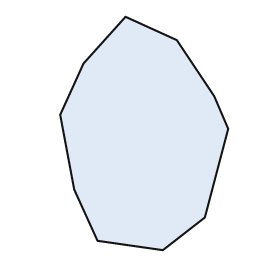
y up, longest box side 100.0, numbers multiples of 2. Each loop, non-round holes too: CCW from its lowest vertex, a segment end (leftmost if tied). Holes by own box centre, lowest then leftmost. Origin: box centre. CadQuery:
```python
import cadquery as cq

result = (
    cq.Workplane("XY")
    .moveTo(8.0, -50.0)
    .lineTo(26.0, -36.0)
    .lineTo(36.0, 2.0)
    .lineTo(30.0, 16.0)
    .lineTo(14.0, 40.0)
    .lineTo(-8.0, 50.0)
    .lineTo(-26.0, 30.0)
    .lineTo(-36.0, 8.0)
    .lineTo(-30.0, -24.0)
    .lineTo(-20.0, -46.0)
    .close()
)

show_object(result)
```